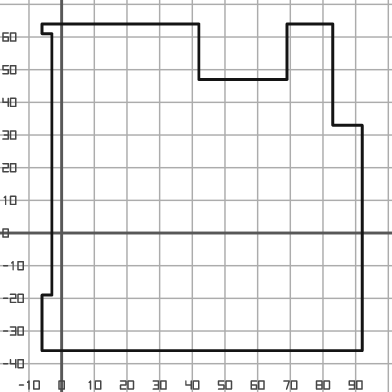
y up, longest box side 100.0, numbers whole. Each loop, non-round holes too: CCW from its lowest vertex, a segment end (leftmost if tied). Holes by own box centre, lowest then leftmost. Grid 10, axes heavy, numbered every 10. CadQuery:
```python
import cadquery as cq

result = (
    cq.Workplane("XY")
    .moveTo(-6.0, -36.0)
    .lineTo(92.0, -36.0)
    .lineTo(92.0, 33.0)
    .lineTo(83.0, 33.0)
    .lineTo(83.0, 64.0)
    .lineTo(69.0, 64.0)
    .lineTo(69.0, 47.0)
    .lineTo(42.0, 47.0)
    .lineTo(42.0, 64.0)
    .lineTo(-6.0, 64.0)
    .lineTo(-6.0, 61.0)
    .lineTo(-3.0, 61.0)
    .lineTo(-3.0, -19.0)
    .lineTo(-6.0, -19.0)
    .close()
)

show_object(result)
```